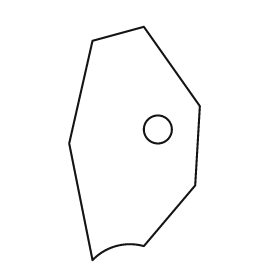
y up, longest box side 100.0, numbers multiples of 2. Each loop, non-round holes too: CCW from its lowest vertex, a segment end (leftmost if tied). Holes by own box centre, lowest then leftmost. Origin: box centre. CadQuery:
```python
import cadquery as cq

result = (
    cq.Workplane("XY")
    .moveTo(-18.0, -50.0)
    .threePointArc((-8.0, -44.0), (4.0, -44.0))
    .lineTo(26.0, -18.0)
    .lineTo(28.0, 16.0)
    .lineTo(4.0, 50.0)
    .lineTo(-18.0, 44.0)
    .lineTo(-28.0, 0.0)
    .close()
    .moveTo(10.0, 6.0)
    .circle(6.0)
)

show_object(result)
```